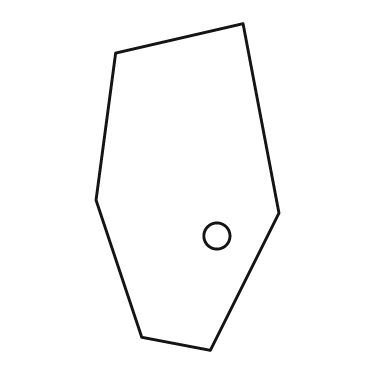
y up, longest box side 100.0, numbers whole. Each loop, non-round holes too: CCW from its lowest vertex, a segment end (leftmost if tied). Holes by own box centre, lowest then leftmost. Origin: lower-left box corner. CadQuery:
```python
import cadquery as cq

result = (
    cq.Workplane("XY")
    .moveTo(35.0, 0.0)
    .lineTo(56.0, 42.0)
    .lineTo(45.0, 100.0)
    .lineTo(6.0, 91.0)
    .lineTo(0.0, 46.0)
    .lineTo(14.0, 4.0)
    .close()
    .moveTo(37.0, 35.0)
    .circle(4.0)
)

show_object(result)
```